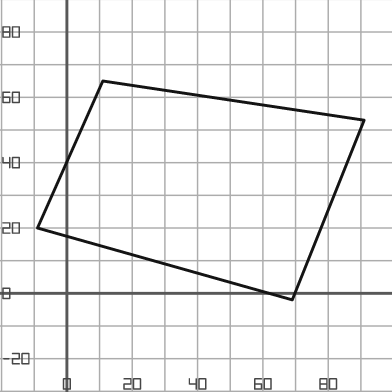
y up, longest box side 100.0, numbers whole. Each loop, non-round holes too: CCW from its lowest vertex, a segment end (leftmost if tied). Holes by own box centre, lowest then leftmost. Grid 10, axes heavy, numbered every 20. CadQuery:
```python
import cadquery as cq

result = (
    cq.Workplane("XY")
    .moveTo(69.0, -2.0)
    .lineTo(91.0, 53.0)
    .lineTo(11.0, 65.0)
    .lineTo(-9.0, 20.0)
    .close()
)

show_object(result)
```